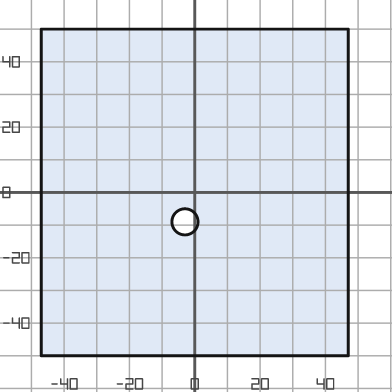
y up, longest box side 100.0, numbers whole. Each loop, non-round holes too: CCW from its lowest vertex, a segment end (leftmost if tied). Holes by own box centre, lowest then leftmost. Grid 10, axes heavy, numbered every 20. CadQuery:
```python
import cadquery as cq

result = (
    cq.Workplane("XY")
    .moveTo(-47.0, -50.0)
    .lineTo(47.0, -50.0)
    .lineTo(47.0, 50.0)
    .lineTo(-47.0, 50.0)
    .close()
    .moveTo(-3.0, -9.0)
    .circle(4.0)
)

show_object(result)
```